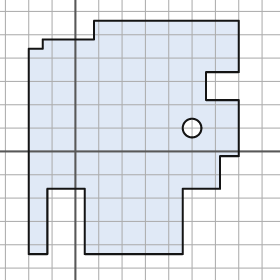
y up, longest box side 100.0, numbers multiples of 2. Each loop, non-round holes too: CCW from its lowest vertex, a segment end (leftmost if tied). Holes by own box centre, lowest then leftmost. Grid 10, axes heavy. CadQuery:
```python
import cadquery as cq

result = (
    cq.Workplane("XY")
    .moveTo(-20.0, -44.0)
    .lineTo(-12.0, -44.0)
    .lineTo(-12.0, -16.0)
    .lineTo(4.0, -16.0)
    .lineTo(4.0, -44.0)
    .lineTo(46.0, -44.0)
    .lineTo(46.0, -16.0)
    .lineTo(62.0, -16.0)
    .lineTo(62.0, -2.0)
    .lineTo(70.0, -2.0)
    .lineTo(70.0, 22.0)
    .lineTo(56.0, 22.0)
    .lineTo(56.0, 34.0)
    .lineTo(70.0, 34.0)
    .lineTo(70.0, 56.0)
    .lineTo(8.0, 56.0)
    .lineTo(8.0, 48.0)
    .lineTo(-14.0, 48.0)
    .lineTo(-14.0, 44.0)
    .lineTo(-20.0, 44.0)
    .close()
    .moveTo(50.0, 10.0)
    .circle(4.0)
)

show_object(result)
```